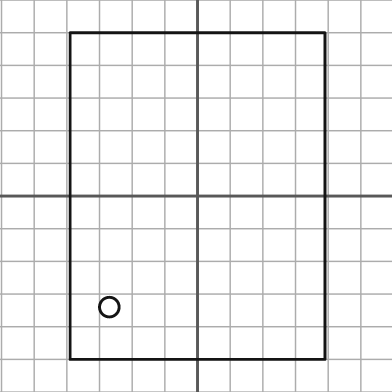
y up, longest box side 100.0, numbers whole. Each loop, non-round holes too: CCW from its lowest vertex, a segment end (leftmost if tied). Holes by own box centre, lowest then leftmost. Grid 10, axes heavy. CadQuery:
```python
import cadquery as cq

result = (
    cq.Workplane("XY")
    .moveTo(-39.0, -50.0)
    .lineTo(39.0, -50.0)
    .lineTo(39.0, 50.0)
    .lineTo(-39.0, 50.0)
    .close()
    .moveTo(-27.0, -34.0)
    .circle(3.0)
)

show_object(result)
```